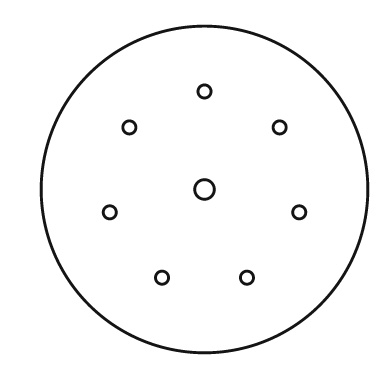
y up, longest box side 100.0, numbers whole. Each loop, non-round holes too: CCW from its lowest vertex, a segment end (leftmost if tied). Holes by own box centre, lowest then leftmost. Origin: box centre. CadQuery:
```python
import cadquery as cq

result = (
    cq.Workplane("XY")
    .moveTo(0.0, 0.0)
    .circle(50.0)
    .moveTo(-13.0, -27.0)
    .circle(2.0)
    .moveTo(13.0, -27.0)
    .circle(2.0)
    .moveTo(-29.0, -7.0)
    .circle(2.0)
    .moveTo(29.0, -7.0)
    .circle(2.0)
    .moveTo(0.0, 0.0)
    .circle(3.0)
    .moveTo(-23.0, 19.0)
    .circle(2.0)
    .moveTo(23.0, 19.0)
    .circle(2.0)
    .moveTo(0.0, 30.0)
    .circle(2.0)
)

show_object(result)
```